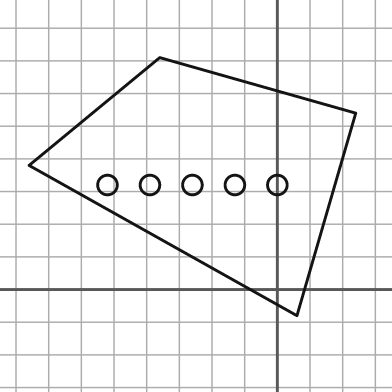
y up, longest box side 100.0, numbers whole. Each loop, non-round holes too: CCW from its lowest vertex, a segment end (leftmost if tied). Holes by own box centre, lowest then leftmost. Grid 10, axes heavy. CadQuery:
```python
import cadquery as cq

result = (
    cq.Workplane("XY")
    .moveTo(6.0, -8.0)
    .lineTo(24.0, 54.0)
    .lineTo(-36.0, 71.0)
    .lineTo(-76.0, 38.0)
    .close()
    .moveTo(-52.0, 32.0)
    .circle(3.0)
    .moveTo(-39.0, 32.0)
    .circle(3.0)
    .moveTo(-26.0, 32.0)
    .circle(3.0)
    .moveTo(-13.0, 32.0)
    .circle(3.0)
    .moveTo(0.0, 32.0)
    .circle(3.0)
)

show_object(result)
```